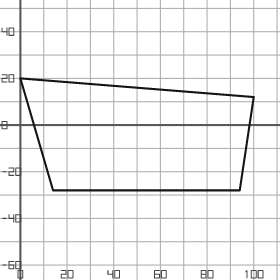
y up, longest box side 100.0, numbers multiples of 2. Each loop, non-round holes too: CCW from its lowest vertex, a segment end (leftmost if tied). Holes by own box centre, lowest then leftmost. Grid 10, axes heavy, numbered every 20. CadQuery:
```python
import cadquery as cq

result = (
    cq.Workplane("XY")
    .moveTo(14.0, -28.0)
    .lineTo(94.0, -28.0)
    .lineTo(100.0, 12.0)
    .lineTo(0.0, 20.0)
    .close()
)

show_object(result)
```